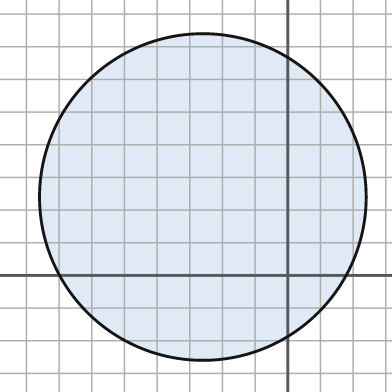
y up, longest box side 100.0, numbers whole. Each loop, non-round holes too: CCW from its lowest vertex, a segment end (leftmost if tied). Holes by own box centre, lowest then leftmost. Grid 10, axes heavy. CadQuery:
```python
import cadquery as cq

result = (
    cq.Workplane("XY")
    .moveTo(-26.0, 24.0)
    .circle(50.0)
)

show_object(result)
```